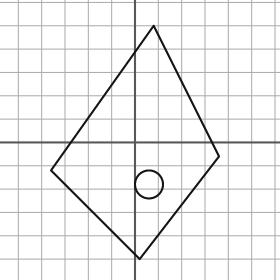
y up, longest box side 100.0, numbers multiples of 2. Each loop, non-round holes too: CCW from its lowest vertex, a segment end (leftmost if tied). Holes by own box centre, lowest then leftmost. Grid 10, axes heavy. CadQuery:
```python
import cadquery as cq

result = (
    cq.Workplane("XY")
    .moveTo(2.0, -50.0)
    .lineTo(36.0, -6.0)
    .lineTo(8.0, 50.0)
    .lineTo(-36.0, -12.0)
    .close()
    .moveTo(6.0, -18.0)
    .circle(6.0)
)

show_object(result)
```